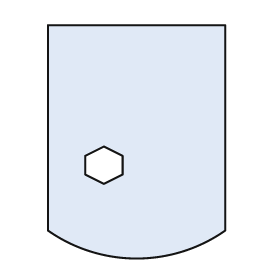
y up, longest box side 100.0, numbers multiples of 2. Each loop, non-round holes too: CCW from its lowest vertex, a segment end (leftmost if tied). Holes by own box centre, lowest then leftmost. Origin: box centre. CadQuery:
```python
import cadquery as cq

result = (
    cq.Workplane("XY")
    .moveTo(-38.0, -38.0)
    .threePointArc((0.0, -50.0), (38.0, -38.0))
    .lineTo(38.0, 50.0)
    .lineTo(-38.0, 50.0)
    .close()
    .moveTo(-14.0, -18.0)
    .lineTo(-6.0, -14.0)
    .lineTo(-6.0, -6.0)
    .lineTo(-14.0, -2.0)
    .lineTo(-22.0, -6.0)
    .lineTo(-22.0, -14.0)
    .close()
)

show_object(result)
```